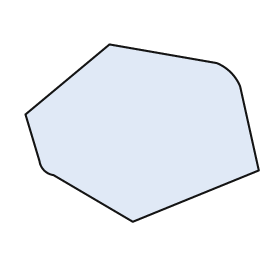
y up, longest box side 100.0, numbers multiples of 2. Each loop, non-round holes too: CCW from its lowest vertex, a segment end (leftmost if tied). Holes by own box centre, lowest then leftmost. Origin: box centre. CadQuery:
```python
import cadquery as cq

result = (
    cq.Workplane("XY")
    .moveTo(-4.0, -38.0)
    .lineTo(50.0, -16.0)
    .lineTo(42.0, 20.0)
    .threePointArc((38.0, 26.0), (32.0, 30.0))
    .lineTo(-14.0, 38.0)
    .lineTo(-50.0, 8.0)
    .lineTo(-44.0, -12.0)
    .threePointArc((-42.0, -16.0), (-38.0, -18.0))
    .close()
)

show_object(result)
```